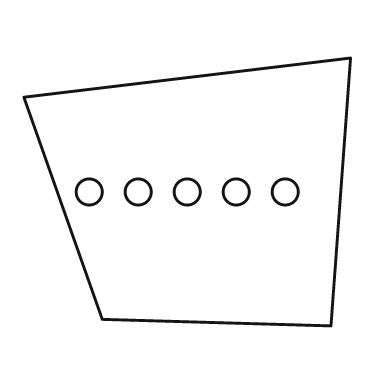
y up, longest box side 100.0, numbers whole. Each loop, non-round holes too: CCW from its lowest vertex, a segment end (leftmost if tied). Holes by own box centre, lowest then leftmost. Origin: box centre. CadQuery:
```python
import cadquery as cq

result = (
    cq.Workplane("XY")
    .moveTo(44.0, -41.0)
    .lineTo(50.0, 41.0)
    .lineTo(-50.0, 29.0)
    .lineTo(-26.0, -39.0)
    .close()
    .moveTo(-30.0, 0.0)
    .circle(4.0)
    .moveTo(-15.0, 0.0)
    .circle(4.0)
    .moveTo(0.0, 0.0)
    .circle(4.0)
    .moveTo(15.0, 0.0)
    .circle(4.0)
    .moveTo(30.0, 0.0)
    .circle(4.0)
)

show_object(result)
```